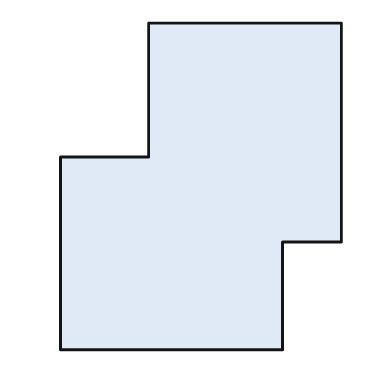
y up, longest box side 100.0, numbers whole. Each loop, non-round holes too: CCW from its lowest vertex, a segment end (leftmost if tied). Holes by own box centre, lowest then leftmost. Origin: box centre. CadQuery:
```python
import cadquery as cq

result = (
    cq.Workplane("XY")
    .moveTo(-43.0, -50.0)
    .lineTo(25.0, -50.0)
    .lineTo(25.0, -17.0)
    .lineTo(43.0, -17.0)
    .lineTo(43.0, 50.0)
    .lineTo(-16.0, 50.0)
    .lineTo(-16.0, 9.0)
    .lineTo(-43.0, 9.0)
    .close()
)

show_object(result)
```